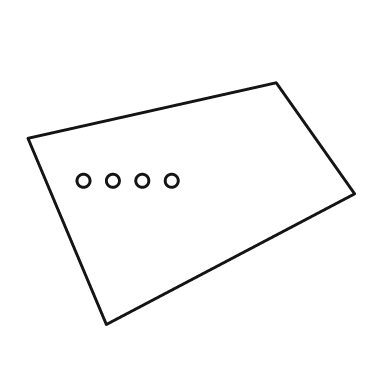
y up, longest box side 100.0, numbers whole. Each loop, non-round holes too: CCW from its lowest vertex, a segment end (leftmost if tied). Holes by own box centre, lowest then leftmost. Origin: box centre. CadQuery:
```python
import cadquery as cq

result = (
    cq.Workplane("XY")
    .moveTo(-26.0, -37.0)
    .lineTo(50.0, 3.0)
    .lineTo(26.0, 37.0)
    .lineTo(-50.0, 20.0)
    .close()
    .moveTo(-33.0, 7.0)
    .circle(2.0)
    .moveTo(-24.0, 7.0)
    .circle(2.0)
    .moveTo(-15.0, 7.0)
    .circle(2.0)
    .moveTo(-6.0, 7.0)
    .circle(2.0)
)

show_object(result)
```